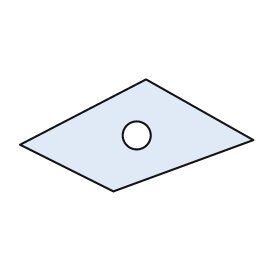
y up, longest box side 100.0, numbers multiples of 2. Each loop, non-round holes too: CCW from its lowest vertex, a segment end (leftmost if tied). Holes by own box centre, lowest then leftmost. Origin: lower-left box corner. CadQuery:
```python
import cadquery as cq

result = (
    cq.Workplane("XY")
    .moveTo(40.0, 0.0)
    .lineTo(100.0, 22.0)
    .lineTo(54.0, 48.0)
    .lineTo(0.0, 20.0)
    .close()
    .moveTo(50.0, 24.0)
    .circle(6.0)
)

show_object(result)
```